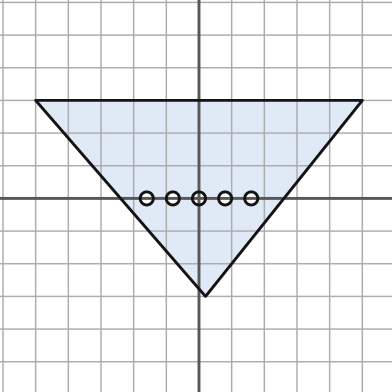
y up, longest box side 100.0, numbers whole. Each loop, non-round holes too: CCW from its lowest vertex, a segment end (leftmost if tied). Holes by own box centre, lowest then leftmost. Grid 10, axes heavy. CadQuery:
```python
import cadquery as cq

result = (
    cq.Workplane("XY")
    .moveTo(2.0, -30.0)
    .lineTo(50.0, 30.0)
    .lineTo(-50.0, 30.0)
    .close()
    .moveTo(-16.0, 0.0)
    .circle(2.0)
    .moveTo(-8.0, 0.0)
    .circle(2.0)
    .moveTo(0.0, 0.0)
    .circle(2.0)
    .moveTo(8.0, 0.0)
    .circle(2.0)
    .moveTo(16.0, 0.0)
    .circle(2.0)
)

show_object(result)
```